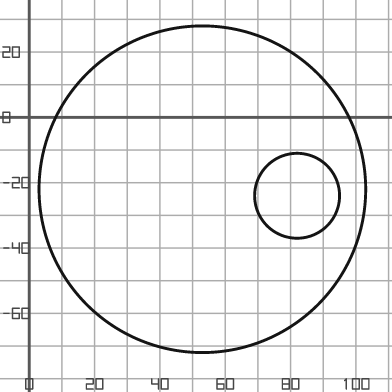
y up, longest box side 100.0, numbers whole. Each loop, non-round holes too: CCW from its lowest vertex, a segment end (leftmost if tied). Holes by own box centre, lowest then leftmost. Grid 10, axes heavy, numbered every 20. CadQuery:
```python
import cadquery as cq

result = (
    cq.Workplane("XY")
    .moveTo(53.0, -22.0)
    .circle(50.0)
    .moveTo(82.0, -24.0)
    .circle(13.0)
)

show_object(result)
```